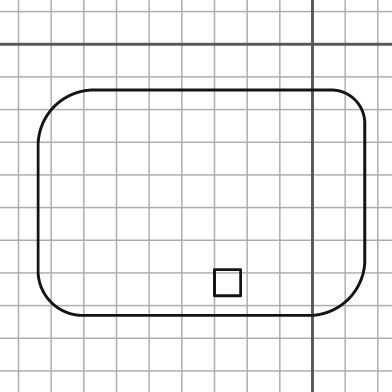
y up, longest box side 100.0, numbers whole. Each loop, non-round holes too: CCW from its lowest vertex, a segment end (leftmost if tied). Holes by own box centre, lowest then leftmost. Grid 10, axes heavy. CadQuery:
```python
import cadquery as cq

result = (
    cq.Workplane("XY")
    .moveTo(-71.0, -83.0)
    .lineTo(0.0, -83.0)
    .threePointArc((11.0, -78.0), (16.0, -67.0))
    .lineTo(16.0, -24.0)
    .threePointArc((13.0, -17.0), (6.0, -14.0))
    .lineTo(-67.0, -14.0)
    .threePointArc((-79.0, -19.0), (-84.0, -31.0))
    .lineTo(-84.0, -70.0)
    .threePointArc((-80.0, -79.0), (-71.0, -83.0))
    .close()
    .moveTo(-30.0, -77.0)
    .lineTo(-22.0, -77.0)
    .lineTo(-22.0, -69.0)
    .lineTo(-30.0, -69.0)
    .close()
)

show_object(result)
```